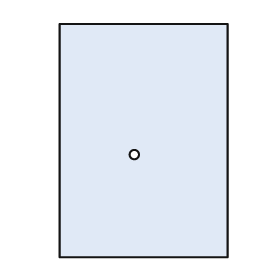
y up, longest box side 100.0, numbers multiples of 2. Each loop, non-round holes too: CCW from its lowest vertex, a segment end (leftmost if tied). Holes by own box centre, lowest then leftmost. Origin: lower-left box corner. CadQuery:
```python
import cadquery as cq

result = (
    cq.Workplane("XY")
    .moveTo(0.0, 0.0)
    .lineTo(72.0, 0.0)
    .lineTo(72.0, 100.0)
    .lineTo(0.0, 100.0)
    .close()
    .moveTo(32.0, 44.0)
    .circle(2.0)
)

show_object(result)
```